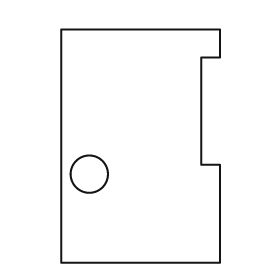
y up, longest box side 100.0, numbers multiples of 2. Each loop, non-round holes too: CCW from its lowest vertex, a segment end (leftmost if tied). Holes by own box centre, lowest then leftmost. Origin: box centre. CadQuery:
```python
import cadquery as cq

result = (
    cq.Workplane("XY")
    .moveTo(-34.0, -50.0)
    .lineTo(34.0, -50.0)
    .lineTo(34.0, -8.0)
    .lineTo(26.0, -8.0)
    .lineTo(26.0, 38.0)
    .lineTo(34.0, 38.0)
    .lineTo(34.0, 50.0)
    .lineTo(-34.0, 50.0)
    .close()
    .moveTo(-22.0, -12.0)
    .circle(8.0)
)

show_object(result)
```